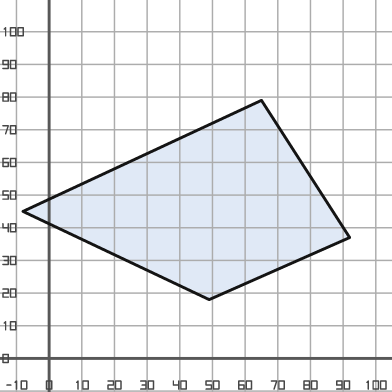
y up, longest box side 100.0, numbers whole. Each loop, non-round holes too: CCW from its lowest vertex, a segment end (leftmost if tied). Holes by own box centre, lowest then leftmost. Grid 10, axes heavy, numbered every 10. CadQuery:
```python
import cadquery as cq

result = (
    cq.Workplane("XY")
    .moveTo(49.0, 18.0)
    .lineTo(92.0, 37.0)
    .lineTo(65.0, 79.0)
    .lineTo(-8.0, 45.0)
    .close()
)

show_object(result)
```